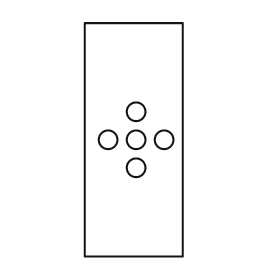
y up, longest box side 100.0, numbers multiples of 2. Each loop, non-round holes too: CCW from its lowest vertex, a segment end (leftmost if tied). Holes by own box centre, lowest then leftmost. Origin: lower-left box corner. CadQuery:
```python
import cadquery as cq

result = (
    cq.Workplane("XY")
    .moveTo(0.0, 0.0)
    .lineTo(42.0, 0.0)
    .lineTo(42.0, 100.0)
    .lineTo(0.0, 100.0)
    .close()
    .moveTo(22.0, 38.0)
    .circle(4.0)
    .moveTo(10.0, 50.0)
    .circle(4.0)
    .moveTo(22.0, 50.0)
    .circle(4.0)
    .moveTo(34.0, 50.0)
    .circle(4.0)
    .moveTo(22.0, 62.0)
    .circle(4.0)
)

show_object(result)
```